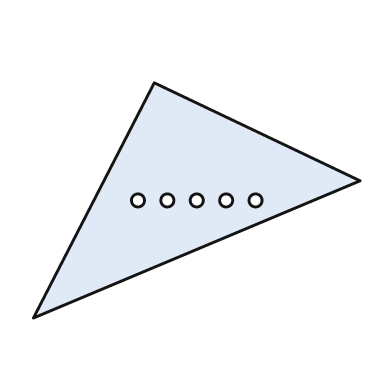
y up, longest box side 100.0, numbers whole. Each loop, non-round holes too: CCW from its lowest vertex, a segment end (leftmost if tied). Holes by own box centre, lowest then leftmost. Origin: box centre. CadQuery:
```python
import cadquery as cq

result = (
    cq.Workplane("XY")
    .moveTo(-50.0, -36.0)
    .lineTo(50.0, 6.0)
    .lineTo(-13.0, 36.0)
    .close()
    .moveTo(-18.0, 0.0)
    .circle(2.0)
    .moveTo(-9.0, 0.0)
    .circle(2.0)
    .moveTo(0.0, 0.0)
    .circle(2.0)
    .moveTo(9.0, 0.0)
    .circle(2.0)
    .moveTo(18.0, 0.0)
    .circle(2.0)
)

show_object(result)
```